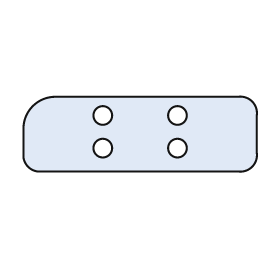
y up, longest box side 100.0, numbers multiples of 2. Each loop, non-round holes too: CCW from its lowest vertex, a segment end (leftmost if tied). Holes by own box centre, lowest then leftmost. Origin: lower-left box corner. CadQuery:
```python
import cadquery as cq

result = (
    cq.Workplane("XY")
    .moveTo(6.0, 0.0)
    .lineTo(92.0, 0.0)
    .threePointArc((98.0, 2.0), (100.0, 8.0))
    .lineTo(100.0, 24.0)
    .threePointArc((98.0, 30.0), (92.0, 32.0))
    .lineTo(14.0, 32.0)
    .threePointArc((4.0, 28.0), (0.0, 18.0))
    .lineTo(0.0, 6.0)
    .threePointArc((2.0, 2.0), (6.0, 0.0))
    .close()
    .moveTo(34.0, 10.0)
    .circle(4.0)
    .moveTo(66.0, 10.0)
    .circle(4.0)
    .moveTo(34.0, 24.0)
    .circle(4.0)
    .moveTo(66.0, 24.0)
    .circle(4.0)
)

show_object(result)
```